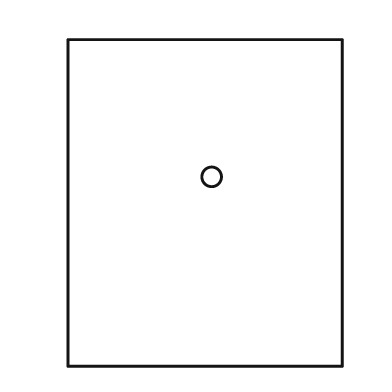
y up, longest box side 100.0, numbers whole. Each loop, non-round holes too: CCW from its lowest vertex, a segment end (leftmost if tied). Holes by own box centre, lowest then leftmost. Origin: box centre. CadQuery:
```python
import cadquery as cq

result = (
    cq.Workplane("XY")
    .moveTo(-42.0, -50.0)
    .lineTo(42.0, -50.0)
    .lineTo(42.0, 50.0)
    .lineTo(-42.0, 50.0)
    .close()
    .moveTo(2.0, 8.0)
    .circle(3.0)
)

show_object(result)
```